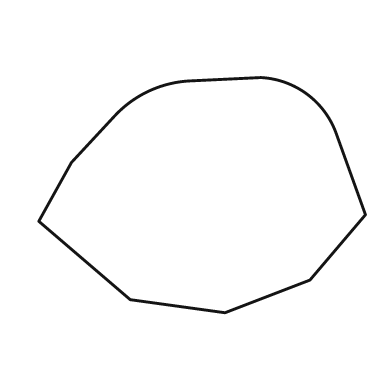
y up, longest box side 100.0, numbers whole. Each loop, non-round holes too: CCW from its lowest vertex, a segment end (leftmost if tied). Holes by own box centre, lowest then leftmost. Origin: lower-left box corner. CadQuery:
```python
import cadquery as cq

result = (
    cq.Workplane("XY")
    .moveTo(57.0, 0.0)
    .lineTo(83.0, 10.0)
    .lineTo(100.0, 30.0)
    .lineTo(91.0, 55.0)
    .threePointArc((82.0, 67.0), (68.0, 72.0))
    .lineTo(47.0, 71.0)
    .threePointArc((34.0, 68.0), (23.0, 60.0))
    .lineTo(10.0, 46.0)
    .lineTo(0.0, 28.0)
    .lineTo(28.0, 4.0)
    .close()
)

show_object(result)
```